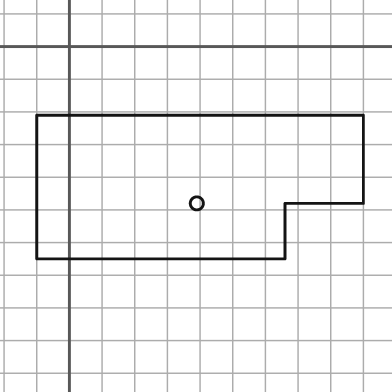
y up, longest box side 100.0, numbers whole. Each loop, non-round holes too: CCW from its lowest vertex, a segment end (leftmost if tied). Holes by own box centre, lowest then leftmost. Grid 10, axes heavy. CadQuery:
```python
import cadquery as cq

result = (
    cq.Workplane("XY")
    .moveTo(-10.0, -65.0)
    .lineTo(66.0, -65.0)
    .lineTo(66.0, -48.0)
    .lineTo(90.0, -48.0)
    .lineTo(90.0, -21.0)
    .lineTo(-10.0, -21.0)
    .close()
    .moveTo(39.0, -48.0)
    .circle(2.0)
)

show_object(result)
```